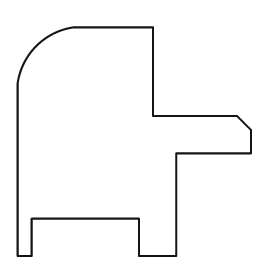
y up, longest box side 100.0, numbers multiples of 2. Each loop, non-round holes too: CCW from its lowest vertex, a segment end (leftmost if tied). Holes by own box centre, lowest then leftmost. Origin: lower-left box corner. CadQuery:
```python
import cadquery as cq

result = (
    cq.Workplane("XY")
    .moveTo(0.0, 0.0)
    .lineTo(6.0, 0.0)
    .lineTo(6.0, 16.0)
    .lineTo(52.0, 16.0)
    .lineTo(52.0, 0.0)
    .lineTo(68.0, 0.0)
    .lineTo(68.0, 44.0)
    .lineTo(100.0, 44.0)
    .lineTo(100.0, 54.0)
    .lineTo(94.0, 60.0)
    .lineTo(58.0, 60.0)
    .lineTo(58.0, 98.0)
    .lineTo(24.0, 98.0)
    .threePointArc((8.0, 90.0), (0.0, 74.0))
    .close()
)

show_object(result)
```